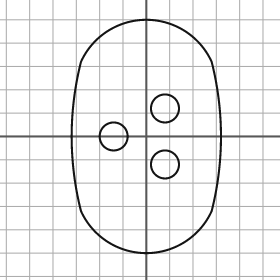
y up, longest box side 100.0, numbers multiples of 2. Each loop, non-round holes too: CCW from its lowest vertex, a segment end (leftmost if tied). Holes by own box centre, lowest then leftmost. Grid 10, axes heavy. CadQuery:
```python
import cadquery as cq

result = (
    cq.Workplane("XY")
    .moveTo(-28.0, -32.0)
    .threePointArc((0.0, -50.0), (28.0, -32.0))
    .threePointArc((32.0, 0.0), (28.0, 32.0))
    .threePointArc((0.0, 50.0), (-28.0, 32.0))
    .threePointArc((-32.0, 0.0), (-28.0, -32.0))
    .close()
    .moveTo(8.0, -12.0)
    .circle(6.0)
    .moveTo(-14.0, 0.0)
    .circle(6.0)
    .moveTo(8.0, 12.0)
    .circle(6.0)
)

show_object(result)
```